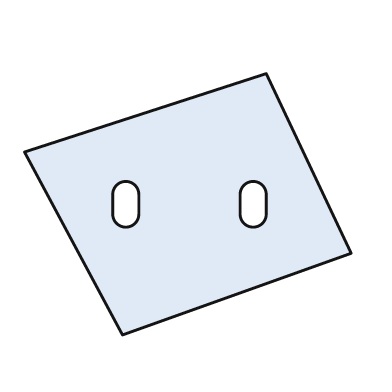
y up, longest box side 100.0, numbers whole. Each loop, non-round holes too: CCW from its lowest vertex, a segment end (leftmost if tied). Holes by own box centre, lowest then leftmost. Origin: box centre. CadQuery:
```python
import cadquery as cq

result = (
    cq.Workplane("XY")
    .moveTo(-20.0, -40.0)
    .lineTo(50.0, -15.0)
    .lineTo(24.0, 40.0)
    .lineTo(-50.0, 16.0)
    .close()
    .moveTo(-23.0, -3.0)
    .threePointArc((-19.0, -7.0), (-15.0, -3.0))
    .lineTo(-15.0, 3.0)
    .threePointArc((-19.0, 7.0), (-23.0, 3.0))
    .close()
    .moveTo(16.0, -3.0)
    .threePointArc((20.0, -7.0), (24.0, -3.0))
    .lineTo(24.0, 3.0)
    .threePointArc((20.0, 7.0), (16.0, 3.0))
    .close()
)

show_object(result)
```